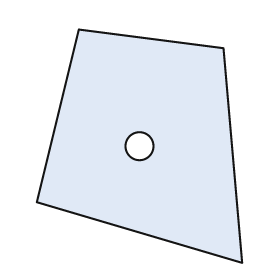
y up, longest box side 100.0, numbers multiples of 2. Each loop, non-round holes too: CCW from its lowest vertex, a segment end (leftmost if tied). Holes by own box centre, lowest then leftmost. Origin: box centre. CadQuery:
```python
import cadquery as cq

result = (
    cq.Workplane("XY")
    .moveTo(44.0, -50.0)
    .lineTo(36.0, 42.0)
    .lineTo(-26.0, 50.0)
    .lineTo(-44.0, -24.0)
    .close()
    .moveTo(0.0, 0.0)
    .circle(6.0)
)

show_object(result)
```